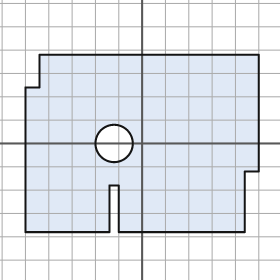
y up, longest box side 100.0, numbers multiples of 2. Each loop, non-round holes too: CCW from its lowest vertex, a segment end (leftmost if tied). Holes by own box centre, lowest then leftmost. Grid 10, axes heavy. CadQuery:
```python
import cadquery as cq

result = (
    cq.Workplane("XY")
    .moveTo(-50.0, -38.0)
    .lineTo(-14.0, -38.0)
    .lineTo(-14.0, -18.0)
    .lineTo(-10.0, -18.0)
    .lineTo(-10.0, -38.0)
    .lineTo(44.0, -38.0)
    .lineTo(44.0, -12.0)
    .lineTo(50.0, -12.0)
    .lineTo(50.0, 38.0)
    .lineTo(-44.0, 38.0)
    .lineTo(-44.0, 24.0)
    .lineTo(-50.0, 24.0)
    .close()
    .moveTo(-12.0, 0.0)
    .circle(8.0)
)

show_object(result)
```